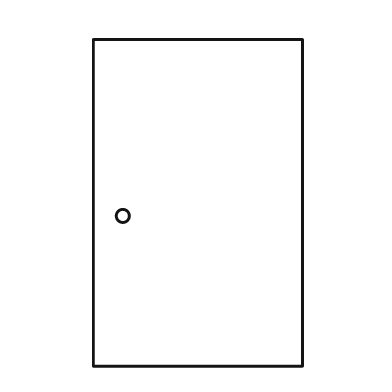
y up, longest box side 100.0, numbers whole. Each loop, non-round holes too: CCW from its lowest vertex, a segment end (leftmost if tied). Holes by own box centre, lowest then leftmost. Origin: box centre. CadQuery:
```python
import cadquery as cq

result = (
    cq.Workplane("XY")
    .moveTo(-32.0, -50.0)
    .lineTo(32.0, -50.0)
    .lineTo(32.0, 50.0)
    .lineTo(-32.0, 50.0)
    .close()
    .moveTo(-23.0, -4.0)
    .circle(2.0)
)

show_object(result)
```